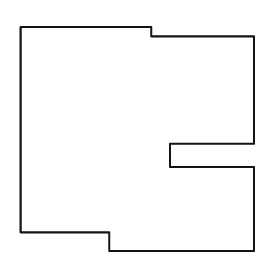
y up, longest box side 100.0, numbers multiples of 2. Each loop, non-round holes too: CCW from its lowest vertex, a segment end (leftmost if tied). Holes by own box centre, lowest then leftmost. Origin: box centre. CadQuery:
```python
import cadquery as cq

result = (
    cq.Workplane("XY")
    .moveTo(-12.0, -48.0)
    .lineTo(50.0, -48.0)
    .lineTo(50.0, -12.0)
    .lineTo(14.0, -12.0)
    .lineTo(14.0, -2.0)
    .lineTo(50.0, -2.0)
    .lineTo(50.0, 44.0)
    .lineTo(6.0, 44.0)
    .lineTo(6.0, 48.0)
    .lineTo(-50.0, 48.0)
    .lineTo(-50.0, -40.0)
    .lineTo(-12.0, -40.0)
    .close()
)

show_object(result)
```